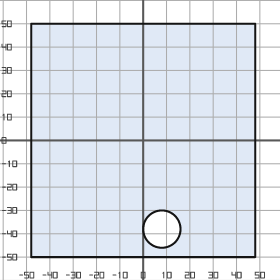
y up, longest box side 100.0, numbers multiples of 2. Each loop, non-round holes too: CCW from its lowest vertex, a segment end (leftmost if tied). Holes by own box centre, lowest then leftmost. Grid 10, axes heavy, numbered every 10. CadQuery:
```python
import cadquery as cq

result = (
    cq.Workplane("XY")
    .moveTo(-48.0, -50.0)
    .lineTo(48.0, -50.0)
    .lineTo(48.0, 50.0)
    .lineTo(-48.0, 50.0)
    .close()
    .moveTo(8.0, -38.0)
    .circle(8.0)
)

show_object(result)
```